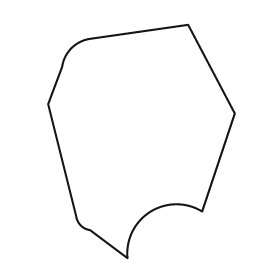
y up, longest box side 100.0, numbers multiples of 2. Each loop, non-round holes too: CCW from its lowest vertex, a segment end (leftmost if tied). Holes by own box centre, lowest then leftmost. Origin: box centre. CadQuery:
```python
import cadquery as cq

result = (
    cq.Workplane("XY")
    .moveTo(-6.0, -50.0)
    .threePointArc((4.0, -30.0), (26.0, -30.0))
    .lineTo(40.0, 12.0)
    .lineTo(20.0, 50.0)
    .lineTo(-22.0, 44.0)
    .threePointArc((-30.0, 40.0), (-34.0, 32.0))
    .lineTo(-40.0, 16.0)
    .lineTo(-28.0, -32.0)
    .threePointArc((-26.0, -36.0), (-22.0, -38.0))
    .close()
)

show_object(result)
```